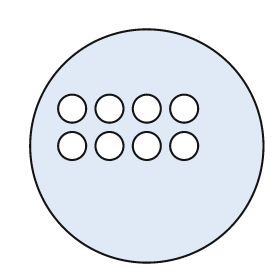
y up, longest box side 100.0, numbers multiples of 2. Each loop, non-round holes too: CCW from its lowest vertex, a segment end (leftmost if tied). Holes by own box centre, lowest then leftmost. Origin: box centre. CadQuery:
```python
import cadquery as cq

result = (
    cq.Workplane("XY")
    .moveTo(0.0, 0.0)
    .circle(50.0)
    .moveTo(-32.0, 0.0)
    .circle(6.0)
    .moveTo(-16.0, 0.0)
    .circle(6.0)
    .moveTo(0.0, 0.0)
    .circle(6.0)
    .moveTo(16.0, 0.0)
    .circle(6.0)
    .moveTo(-32.0, 16.0)
    .circle(6.0)
    .moveTo(-16.0, 16.0)
    .circle(6.0)
    .moveTo(0.0, 16.0)
    .circle(6.0)
    .moveTo(16.0, 16.0)
    .circle(6.0)
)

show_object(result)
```